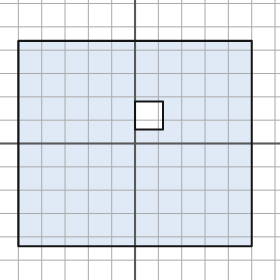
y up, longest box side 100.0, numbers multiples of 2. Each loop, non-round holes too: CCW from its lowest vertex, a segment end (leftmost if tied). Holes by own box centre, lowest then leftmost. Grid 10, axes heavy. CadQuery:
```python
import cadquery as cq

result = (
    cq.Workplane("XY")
    .moveTo(-50.0, -44.0)
    .lineTo(50.0, -44.0)
    .lineTo(50.0, 44.0)
    .lineTo(-50.0, 44.0)
    .close()
    .moveTo(0.0, 6.0)
    .lineTo(12.0, 6.0)
    .lineTo(12.0, 18.0)
    .lineTo(0.0, 18.0)
    .close()
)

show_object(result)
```